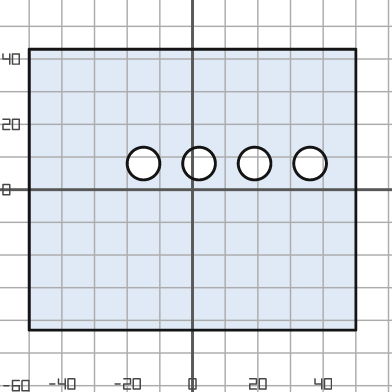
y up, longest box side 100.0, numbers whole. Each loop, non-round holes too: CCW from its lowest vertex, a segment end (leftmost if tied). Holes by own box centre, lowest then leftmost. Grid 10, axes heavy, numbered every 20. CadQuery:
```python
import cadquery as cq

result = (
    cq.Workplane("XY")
    .moveTo(-50.0, -43.0)
    .lineTo(50.0, -43.0)
    .lineTo(50.0, 43.0)
    .lineTo(-50.0, 43.0)
    .close()
    .moveTo(-15.0, 8.0)
    .circle(5.0)
    .moveTo(2.0, 8.0)
    .circle(5.0)
    .moveTo(19.0, 8.0)
    .circle(5.0)
    .moveTo(36.0, 8.0)
    .circle(5.0)
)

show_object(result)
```